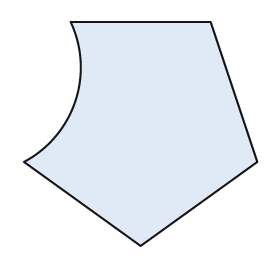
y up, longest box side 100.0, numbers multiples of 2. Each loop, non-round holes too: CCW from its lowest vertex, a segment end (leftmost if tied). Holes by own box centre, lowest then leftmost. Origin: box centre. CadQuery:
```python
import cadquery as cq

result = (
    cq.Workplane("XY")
    .moveTo(0.0, -48.0)
    .lineTo(50.0, -12.0)
    .lineTo(30.0, 48.0)
    .lineTo(-30.0, 48.0)
    .threePointArc((-28.0, 14.0), (-50.0, -12.0))
    .close()
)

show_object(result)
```